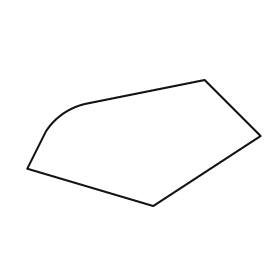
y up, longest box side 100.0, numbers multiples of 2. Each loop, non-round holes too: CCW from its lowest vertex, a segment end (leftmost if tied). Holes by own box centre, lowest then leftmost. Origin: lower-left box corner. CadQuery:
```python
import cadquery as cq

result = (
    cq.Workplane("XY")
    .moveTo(54.0, 0.0)
    .lineTo(100.0, 30.0)
    .lineTo(76.0, 54.0)
    .lineTo(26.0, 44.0)
    .threePointArc((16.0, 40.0), (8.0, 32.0))
    .lineTo(0.0, 16.0)
    .close()
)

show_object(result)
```